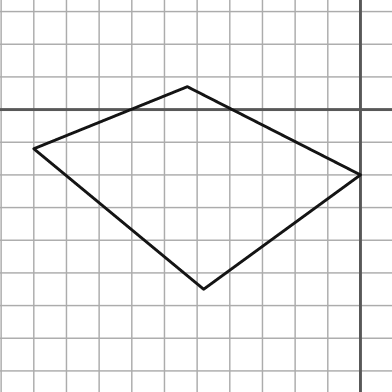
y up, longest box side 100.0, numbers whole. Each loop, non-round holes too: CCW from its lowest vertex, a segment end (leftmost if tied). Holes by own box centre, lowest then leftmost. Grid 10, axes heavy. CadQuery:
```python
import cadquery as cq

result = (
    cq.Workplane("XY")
    .moveTo(-48.0, -55.0)
    .lineTo(0.0, -20.0)
    .lineTo(-53.0, 7.0)
    .lineTo(-100.0, -12.0)
    .close()
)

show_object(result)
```